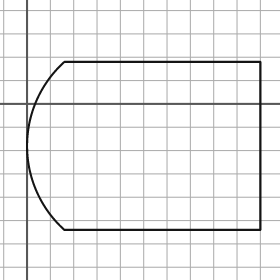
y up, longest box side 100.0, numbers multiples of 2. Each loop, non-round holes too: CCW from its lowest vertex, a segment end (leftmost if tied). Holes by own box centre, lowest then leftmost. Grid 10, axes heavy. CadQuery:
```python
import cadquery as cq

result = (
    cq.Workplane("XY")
    .moveTo(16.0, -54.0)
    .lineTo(100.0, -54.0)
    .lineTo(100.0, 18.0)
    .lineTo(16.0, 18.0)
    .threePointArc((0.0, -18.0), (16.0, -54.0))
    .close()
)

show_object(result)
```